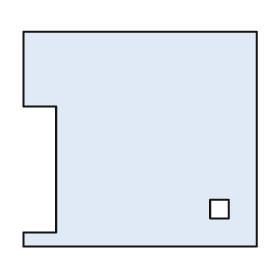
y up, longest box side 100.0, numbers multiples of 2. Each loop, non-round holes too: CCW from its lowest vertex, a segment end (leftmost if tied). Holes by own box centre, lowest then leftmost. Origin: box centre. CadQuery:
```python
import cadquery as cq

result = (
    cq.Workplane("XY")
    .moveTo(-50.0, -46.0)
    .lineTo(50.0, -46.0)
    .lineTo(50.0, 46.0)
    .lineTo(-50.0, 46.0)
    .lineTo(-50.0, 14.0)
    .lineTo(-36.0, 14.0)
    .lineTo(-36.0, -40.0)
    .lineTo(-50.0, -40.0)
    .close()
    .moveTo(30.0, -34.0)
    .lineTo(38.0, -34.0)
    .lineTo(38.0, -26.0)
    .lineTo(30.0, -26.0)
    .close()
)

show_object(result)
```